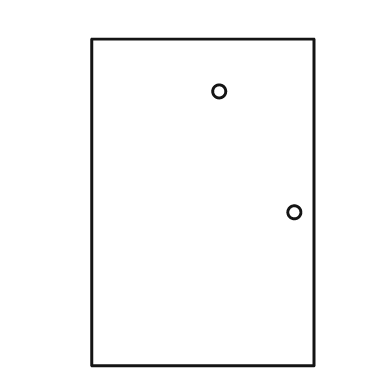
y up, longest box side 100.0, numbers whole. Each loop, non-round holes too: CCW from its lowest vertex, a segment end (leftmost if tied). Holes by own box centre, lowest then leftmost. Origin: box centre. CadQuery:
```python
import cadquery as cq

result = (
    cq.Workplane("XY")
    .moveTo(-34.0, -50.0)
    .lineTo(34.0, -50.0)
    .lineTo(34.0, 50.0)
    .lineTo(-34.0, 50.0)
    .close()
    .moveTo(28.0, -3.0)
    .circle(2.0)
    .moveTo(5.0, 34.0)
    .circle(2.0)
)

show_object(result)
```